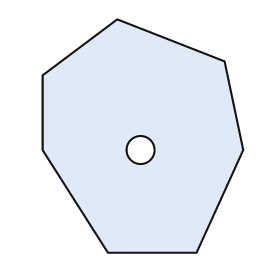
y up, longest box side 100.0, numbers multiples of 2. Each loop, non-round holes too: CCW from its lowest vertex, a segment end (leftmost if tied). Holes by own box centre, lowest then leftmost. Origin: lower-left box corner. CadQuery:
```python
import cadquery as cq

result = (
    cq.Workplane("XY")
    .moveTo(28.0, 0.0)
    .lineTo(66.0, 0.0)
    .lineTo(86.0, 44.0)
    .lineTo(78.0, 82.0)
    .lineTo(32.0, 100.0)
    .lineTo(0.0, 76.0)
    .lineTo(0.0, 44.0)
    .close()
    .moveTo(42.0, 44.0)
    .circle(6.0)
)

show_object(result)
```